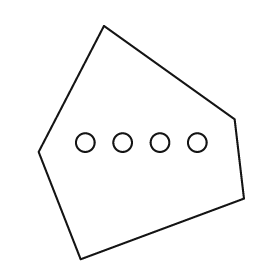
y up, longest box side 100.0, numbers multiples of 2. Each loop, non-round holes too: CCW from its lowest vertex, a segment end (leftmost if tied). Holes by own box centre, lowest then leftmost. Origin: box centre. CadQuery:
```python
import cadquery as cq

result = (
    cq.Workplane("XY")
    .moveTo(-26.0, -50.0)
    .lineTo(44.0, -24.0)
    .lineTo(40.0, 10.0)
    .lineTo(-16.0, 50.0)
    .lineTo(-44.0, -4.0)
    .close()
    .moveTo(-24.0, 0.0)
    .circle(4.0)
    .moveTo(-8.0, 0.0)
    .circle(4.0)
    .moveTo(8.0, 0.0)
    .circle(4.0)
    .moveTo(24.0, 0.0)
    .circle(4.0)
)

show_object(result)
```